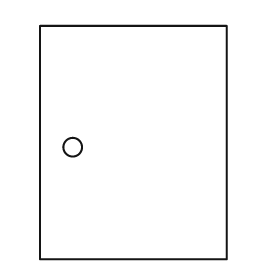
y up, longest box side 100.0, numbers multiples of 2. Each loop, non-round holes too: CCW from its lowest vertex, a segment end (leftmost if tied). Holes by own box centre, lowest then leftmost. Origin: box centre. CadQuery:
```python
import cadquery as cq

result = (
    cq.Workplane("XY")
    .moveTo(-40.0, -50.0)
    .lineTo(40.0, -50.0)
    .lineTo(40.0, 50.0)
    .lineTo(-40.0, 50.0)
    .close()
    .moveTo(-26.0, -2.0)
    .circle(4.0)
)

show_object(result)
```